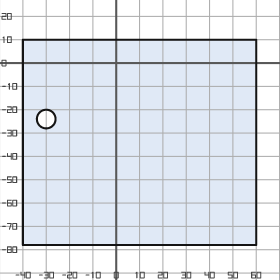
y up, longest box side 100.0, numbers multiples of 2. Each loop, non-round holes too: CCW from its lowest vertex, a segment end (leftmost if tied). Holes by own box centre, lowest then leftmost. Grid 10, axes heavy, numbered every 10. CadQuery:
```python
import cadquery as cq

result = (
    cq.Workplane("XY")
    .moveTo(-40.0, -78.0)
    .lineTo(60.0, -78.0)
    .lineTo(60.0, 10.0)
    .lineTo(-40.0, 10.0)
    .close()
    .moveTo(-30.0, -24.0)
    .circle(4.0)
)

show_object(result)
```